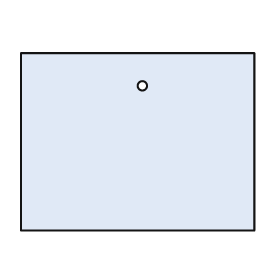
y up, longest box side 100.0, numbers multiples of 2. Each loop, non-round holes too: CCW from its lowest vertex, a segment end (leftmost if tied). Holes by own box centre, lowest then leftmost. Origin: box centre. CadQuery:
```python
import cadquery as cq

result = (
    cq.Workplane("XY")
    .moveTo(-50.0, -38.0)
    .lineTo(50.0, -38.0)
    .lineTo(50.0, 38.0)
    .lineTo(-50.0, 38.0)
    .close()
    .moveTo(2.0, 24.0)
    .circle(2.0)
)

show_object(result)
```